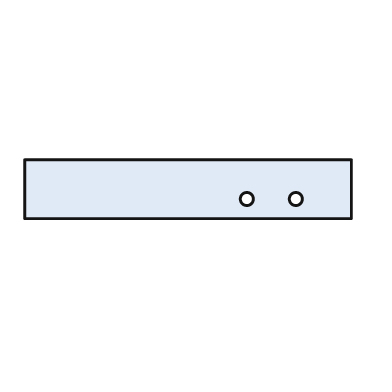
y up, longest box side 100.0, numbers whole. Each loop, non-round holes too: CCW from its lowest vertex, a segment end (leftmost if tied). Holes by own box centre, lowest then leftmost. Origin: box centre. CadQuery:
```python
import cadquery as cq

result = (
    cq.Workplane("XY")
    .moveTo(-50.0, -9.0)
    .lineTo(50.0, -9.0)
    .lineTo(50.0, 9.0)
    .lineTo(-50.0, 9.0)
    .close()
    .moveTo(18.0, -3.0)
    .circle(2.0)
    .moveTo(33.0, -3.0)
    .circle(2.0)
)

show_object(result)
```